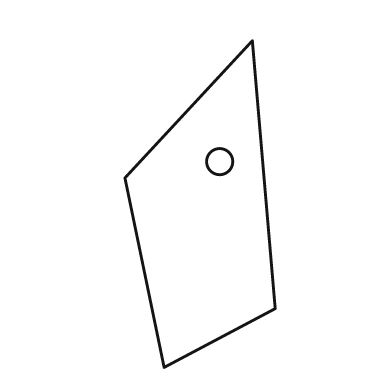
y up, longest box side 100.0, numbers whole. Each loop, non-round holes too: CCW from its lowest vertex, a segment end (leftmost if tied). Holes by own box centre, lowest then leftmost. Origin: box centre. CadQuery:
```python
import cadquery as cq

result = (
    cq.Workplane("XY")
    .moveTo(-11.0, -50.0)
    .lineTo(23.0, -32.0)
    .lineTo(16.0, 50.0)
    .lineTo(-23.0, 8.0)
    .close()
    .moveTo(6.0, 13.0)
    .circle(4.0)
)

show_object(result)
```